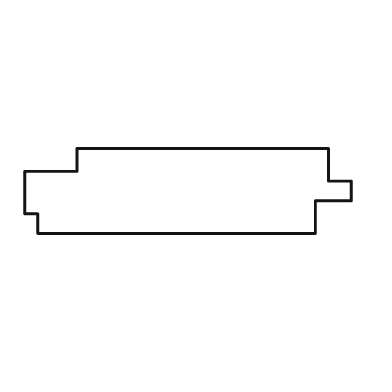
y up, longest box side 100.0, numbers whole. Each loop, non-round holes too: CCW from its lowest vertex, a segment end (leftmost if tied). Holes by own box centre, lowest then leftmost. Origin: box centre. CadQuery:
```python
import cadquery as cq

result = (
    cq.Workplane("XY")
    .moveTo(-46.0, -13.0)
    .lineTo(39.0, -13.0)
    .lineTo(39.0, -3.0)
    .lineTo(50.0, -3.0)
    .lineTo(50.0, 3.0)
    .lineTo(43.0, 3.0)
    .lineTo(43.0, 13.0)
    .lineTo(-34.0, 13.0)
    .lineTo(-34.0, 6.0)
    .lineTo(-50.0, 6.0)
    .lineTo(-50.0, -7.0)
    .lineTo(-46.0, -7.0)
    .close()
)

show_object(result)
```